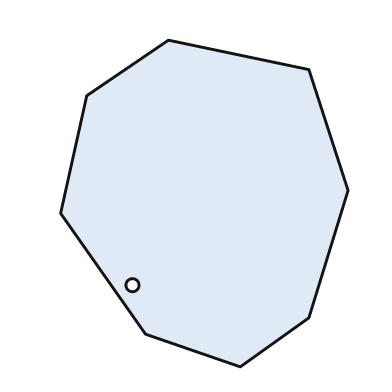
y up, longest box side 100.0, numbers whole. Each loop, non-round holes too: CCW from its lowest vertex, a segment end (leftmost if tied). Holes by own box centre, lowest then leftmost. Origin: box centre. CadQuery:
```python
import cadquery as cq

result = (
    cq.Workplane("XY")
    .moveTo(11.0, -50.0)
    .lineTo(32.0, -35.0)
    .lineTo(44.0, 4.0)
    .lineTo(32.0, 41.0)
    .lineTo(-11.0, 50.0)
    .lineTo(-36.0, 33.0)
    .lineTo(-44.0, -3.0)
    .lineTo(-18.0, -40.0)
    .close()
    .moveTo(-22.0, -25.0)
    .circle(2.0)
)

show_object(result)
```